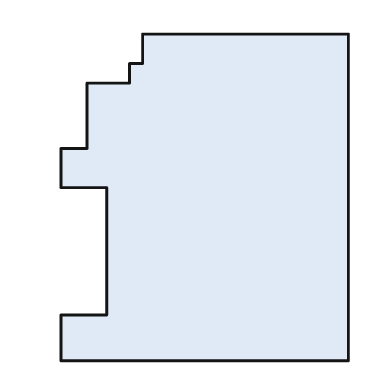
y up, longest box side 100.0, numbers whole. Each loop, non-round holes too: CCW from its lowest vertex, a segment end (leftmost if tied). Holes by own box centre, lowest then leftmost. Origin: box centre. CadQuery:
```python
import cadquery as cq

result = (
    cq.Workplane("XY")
    .moveTo(-44.0, -50.0)
    .lineTo(44.0, -50.0)
    .lineTo(44.0, 50.0)
    .lineTo(-19.0, 50.0)
    .lineTo(-19.0, 41.0)
    .lineTo(-23.0, 41.0)
    .lineTo(-23.0, 35.0)
    .lineTo(-36.0, 35.0)
    .lineTo(-36.0, 15.0)
    .lineTo(-44.0, 15.0)
    .lineTo(-44.0, 3.0)
    .lineTo(-30.0, 3.0)
    .lineTo(-30.0, -36.0)
    .lineTo(-44.0, -36.0)
    .close()
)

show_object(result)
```